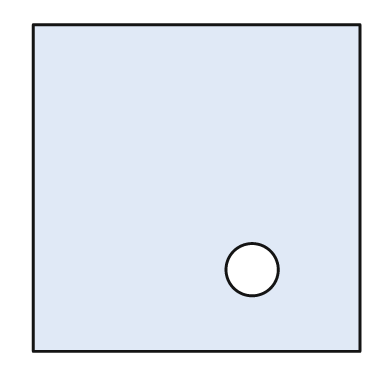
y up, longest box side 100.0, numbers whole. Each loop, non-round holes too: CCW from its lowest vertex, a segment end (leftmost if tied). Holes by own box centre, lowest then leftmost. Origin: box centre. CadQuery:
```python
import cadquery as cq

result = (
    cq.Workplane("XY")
    .moveTo(-50.0, -50.0)
    .lineTo(50.0, -50.0)
    .lineTo(50.0, 50.0)
    .lineTo(-50.0, 50.0)
    .close()
    .moveTo(17.0, -25.0)
    .circle(8.0)
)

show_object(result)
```